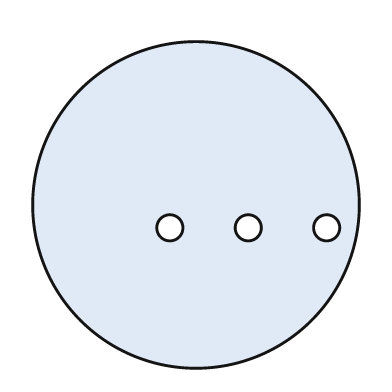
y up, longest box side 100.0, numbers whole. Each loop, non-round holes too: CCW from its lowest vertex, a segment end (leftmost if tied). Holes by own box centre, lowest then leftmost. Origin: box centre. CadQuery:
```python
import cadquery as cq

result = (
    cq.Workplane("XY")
    .moveTo(0.0, 0.0)
    .circle(50.0)
    .moveTo(-8.0, -7.0)
    .circle(4.0)
    .moveTo(16.0, -7.0)
    .circle(4.0)
    .moveTo(40.0, -7.0)
    .circle(4.0)
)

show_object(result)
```